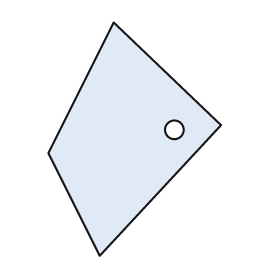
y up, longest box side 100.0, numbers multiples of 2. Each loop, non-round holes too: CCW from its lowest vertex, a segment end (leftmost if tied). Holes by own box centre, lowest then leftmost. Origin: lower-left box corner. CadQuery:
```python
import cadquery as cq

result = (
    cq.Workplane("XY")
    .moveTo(22.0, 0.0)
    .lineTo(74.0, 56.0)
    .lineTo(28.0, 100.0)
    .lineTo(0.0, 44.0)
    .close()
    .moveTo(54.0, 54.0)
    .circle(4.0)
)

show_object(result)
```